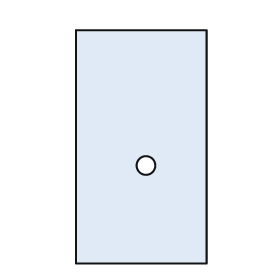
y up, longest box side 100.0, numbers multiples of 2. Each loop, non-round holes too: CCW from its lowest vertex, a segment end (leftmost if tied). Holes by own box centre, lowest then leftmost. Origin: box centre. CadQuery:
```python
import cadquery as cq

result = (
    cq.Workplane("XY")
    .moveTo(-28.0, -50.0)
    .lineTo(28.0, -50.0)
    .lineTo(28.0, 50.0)
    .lineTo(-28.0, 50.0)
    .close()
    .moveTo(2.0, -8.0)
    .circle(4.0)
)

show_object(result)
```